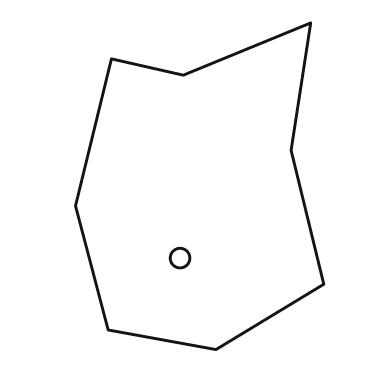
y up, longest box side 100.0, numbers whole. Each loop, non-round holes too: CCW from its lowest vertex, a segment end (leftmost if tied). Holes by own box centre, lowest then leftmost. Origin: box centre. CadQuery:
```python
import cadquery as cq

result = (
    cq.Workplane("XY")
    .moveTo(5.0, -50.0)
    .lineTo(38.0, -30.0)
    .lineTo(28.0, 11.0)
    .lineTo(34.0, 50.0)
    .lineTo(-5.0, 34.0)
    .lineTo(-27.0, 39.0)
    .lineTo(-38.0, -6.0)
    .lineTo(-28.0, -44.0)
    .close()
    .moveTo(-6.0, -22.0)
    .circle(3.0)
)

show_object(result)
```